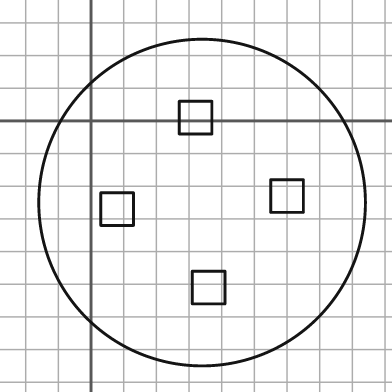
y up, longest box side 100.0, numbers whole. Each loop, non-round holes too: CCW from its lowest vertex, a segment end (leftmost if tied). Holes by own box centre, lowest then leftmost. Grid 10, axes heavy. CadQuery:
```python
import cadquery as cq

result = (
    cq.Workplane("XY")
    .moveTo(34.0, -25.0)
    .circle(50.0)
    .moveTo(31.0, -56.0)
    .lineTo(41.0, -56.0)
    .lineTo(41.0, -46.0)
    .lineTo(31.0, -46.0)
    .close()
    .moveTo(3.0, -32.0)
    .lineTo(13.0, -32.0)
    .lineTo(13.0, -22.0)
    .lineTo(3.0, -22.0)
    .close()
    .moveTo(55.0, -28.0)
    .lineTo(65.0, -28.0)
    .lineTo(65.0, -18.0)
    .lineTo(55.0, -18.0)
    .close()
    .moveTo(27.0, -4.0)
    .lineTo(37.0, -4.0)
    .lineTo(37.0, 6.0)
    .lineTo(27.0, 6.0)
    .close()
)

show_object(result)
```